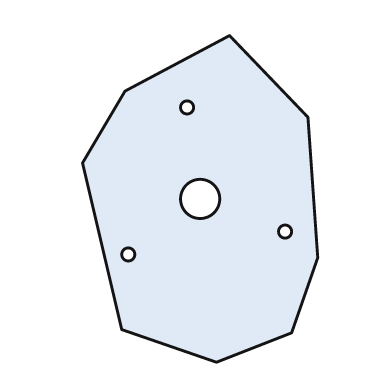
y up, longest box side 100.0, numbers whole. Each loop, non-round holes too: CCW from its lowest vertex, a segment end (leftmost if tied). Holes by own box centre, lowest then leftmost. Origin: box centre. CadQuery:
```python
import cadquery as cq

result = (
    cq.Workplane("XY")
    .moveTo(5.0, -50.0)
    .lineTo(28.0, -41.0)
    .lineTo(36.0, -18.0)
    .lineTo(33.0, 25.0)
    .lineTo(9.0, 50.0)
    .lineTo(-23.0, 33.0)
    .lineTo(-36.0, 11.0)
    .lineTo(-24.0, -40.0)
    .close()
    .moveTo(-22.0, -17.0)
    .circle(2.0)
    .moveTo(26.0, -10.0)
    .circle(2.0)
    .moveTo(0.0, 0.0)
    .circle(6.0)
    .moveTo(-4.0, 28.0)
    .circle(2.0)
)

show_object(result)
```